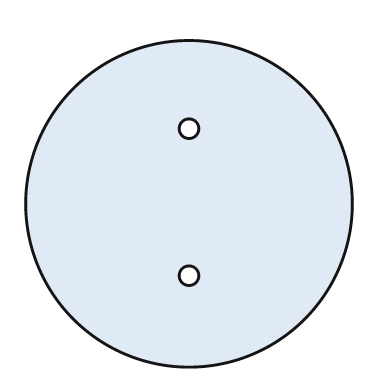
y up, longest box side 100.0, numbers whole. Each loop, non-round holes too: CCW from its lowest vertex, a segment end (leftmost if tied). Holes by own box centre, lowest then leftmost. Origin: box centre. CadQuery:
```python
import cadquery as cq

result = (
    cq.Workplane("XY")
    .moveTo(0.0, 0.0)
    .circle(50.0)
    .moveTo(0.0, -22.0)
    .circle(3.0)
    .moveTo(0.0, 23.0)
    .circle(3.0)
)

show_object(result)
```